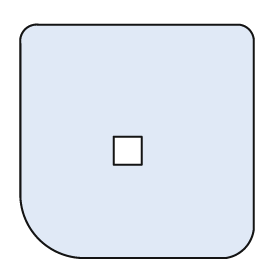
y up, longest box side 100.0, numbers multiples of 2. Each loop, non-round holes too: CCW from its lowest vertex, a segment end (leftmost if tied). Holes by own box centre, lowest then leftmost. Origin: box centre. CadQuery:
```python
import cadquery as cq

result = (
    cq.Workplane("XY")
    .moveTo(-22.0, -50.0)
    .lineTo(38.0, -50.0)
    .threePointArc((46.0, -46.0), (50.0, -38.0))
    .lineTo(50.0, 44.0)
    .threePointArc((48.0, 48.0), (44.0, 50.0))
    .lineTo(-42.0, 50.0)
    .threePointArc((-48.0, 48.0), (-50.0, 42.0))
    .lineTo(-50.0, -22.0)
    .threePointArc((-42.0, -42.0), (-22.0, -50.0))
    .close()
    .moveTo(-10.0, -10.0)
    .lineTo(2.0, -10.0)
    .lineTo(2.0, 2.0)
    .lineTo(-10.0, 2.0)
    .close()
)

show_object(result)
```